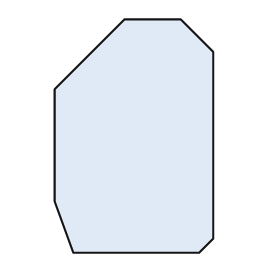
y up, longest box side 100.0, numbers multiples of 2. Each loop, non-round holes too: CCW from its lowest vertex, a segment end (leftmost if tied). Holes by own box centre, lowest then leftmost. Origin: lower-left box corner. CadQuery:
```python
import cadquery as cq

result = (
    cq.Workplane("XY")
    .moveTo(8.0, 0.0)
    .lineTo(62.0, 0.0)
    .lineTo(68.0, 6.0)
    .lineTo(68.0, 86.0)
    .lineTo(54.0, 100.0)
    .lineTo(30.0, 100.0)
    .lineTo(0.0, 70.0)
    .lineTo(0.0, 22.0)
    .close()
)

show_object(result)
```